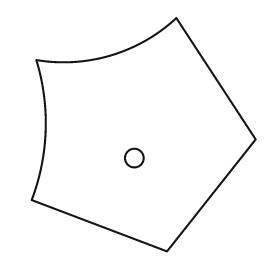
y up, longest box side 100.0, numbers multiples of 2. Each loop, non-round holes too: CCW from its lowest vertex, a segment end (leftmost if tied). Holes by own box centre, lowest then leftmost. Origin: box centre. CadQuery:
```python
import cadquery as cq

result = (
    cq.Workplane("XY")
    .moveTo(10.0, -50.0)
    .lineTo(48.0, -2.0)
    .lineTo(14.0, 50.0)
    .threePointArc((-14.0, 34.0), (-46.0, 32.0))
    .threePointArc((-42.0, 2.0), (-48.0, -28.0))
    .close()
    .moveTo(-4.0, -10.0)
    .circle(4.0)
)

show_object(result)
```